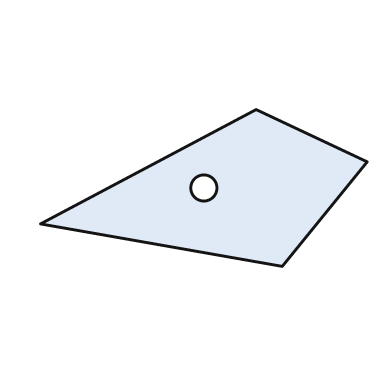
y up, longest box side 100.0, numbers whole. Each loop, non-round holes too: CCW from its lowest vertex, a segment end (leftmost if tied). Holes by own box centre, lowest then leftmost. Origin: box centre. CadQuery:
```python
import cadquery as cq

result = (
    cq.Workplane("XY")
    .moveTo(24.0, -24.0)
    .lineTo(50.0, 8.0)
    .lineTo(16.0, 24.0)
    .lineTo(-50.0, -11.0)
    .close()
    .moveTo(0.0, 0.0)
    .circle(4.0)
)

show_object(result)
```